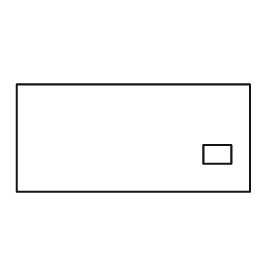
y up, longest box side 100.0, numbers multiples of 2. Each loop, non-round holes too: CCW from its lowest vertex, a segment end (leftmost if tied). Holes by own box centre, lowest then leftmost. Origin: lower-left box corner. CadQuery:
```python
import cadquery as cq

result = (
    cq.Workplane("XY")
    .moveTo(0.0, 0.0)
    .lineTo(100.0, 0.0)
    .lineTo(100.0, 46.0)
    .lineTo(0.0, 46.0)
    .close()
    .moveTo(80.0, 12.0)
    .lineTo(92.0, 12.0)
    .lineTo(92.0, 20.0)
    .lineTo(80.0, 20.0)
    .close()
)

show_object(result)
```